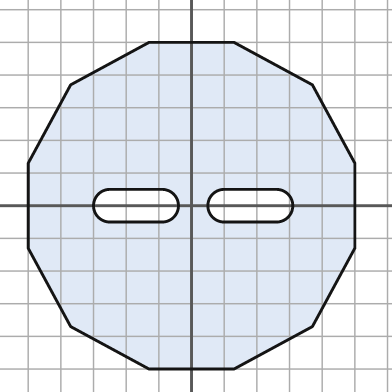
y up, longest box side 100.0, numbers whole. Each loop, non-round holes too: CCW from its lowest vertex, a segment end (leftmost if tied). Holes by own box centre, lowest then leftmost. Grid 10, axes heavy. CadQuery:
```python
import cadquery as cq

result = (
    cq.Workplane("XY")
    .moveTo(-13.0, -50.0)
    .lineTo(13.0, -50.0)
    .lineTo(37.0, -37.0)
    .lineTo(50.0, -13.0)
    .lineTo(50.0, 13.0)
    .lineTo(37.0, 37.0)
    .lineTo(13.0, 50.0)
    .lineTo(-13.0, 50.0)
    .lineTo(-37.0, 37.0)
    .lineTo(-50.0, 13.0)
    .lineTo(-50.0, -13.0)
    .lineTo(-37.0, -37.0)
    .close()
    .moveTo(-25.0, -5.0)
    .lineTo(-9.0, -5.0)
    .threePointArc((-4.0, 0.0), (-9.0, 5.0))
    .lineTo(-25.0, 5.0)
    .threePointArc((-30.0, 0.0), (-25.0, -5.0))
    .close()
    .moveTo(10.0, -5.0)
    .lineTo(26.0, -5.0)
    .threePointArc((31.0, 0.0), (26.0, 5.0))
    .lineTo(10.0, 5.0)
    .threePointArc((5.0, 0.0), (10.0, -5.0))
    .close()
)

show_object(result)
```